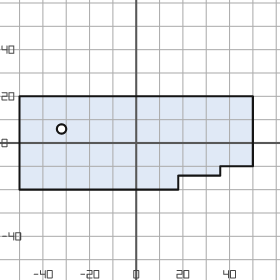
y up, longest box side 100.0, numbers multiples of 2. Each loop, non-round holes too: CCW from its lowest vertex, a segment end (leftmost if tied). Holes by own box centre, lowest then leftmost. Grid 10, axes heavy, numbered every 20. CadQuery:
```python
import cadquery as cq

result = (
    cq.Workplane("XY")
    .moveTo(-50.0, -20.0)
    .lineTo(18.0, -20.0)
    .lineTo(18.0, -14.0)
    .lineTo(36.0, -14.0)
    .lineTo(36.0, -10.0)
    .lineTo(50.0, -10.0)
    .lineTo(50.0, 20.0)
    .lineTo(-50.0, 20.0)
    .close()
    .moveTo(-32.0, 6.0)
    .circle(2.0)
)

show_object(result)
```